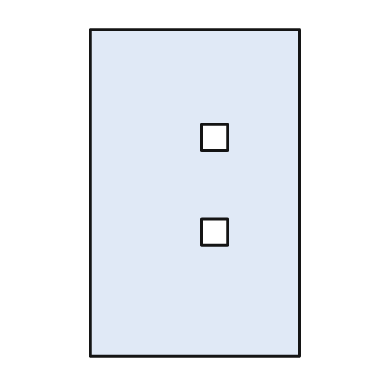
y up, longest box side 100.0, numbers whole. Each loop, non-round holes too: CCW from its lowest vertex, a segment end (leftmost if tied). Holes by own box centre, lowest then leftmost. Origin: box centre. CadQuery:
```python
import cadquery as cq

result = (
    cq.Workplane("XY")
    .moveTo(-32.0, -50.0)
    .lineTo(32.0, -50.0)
    .lineTo(32.0, 50.0)
    .lineTo(-32.0, 50.0)
    .close()
    .moveTo(2.0, -16.0)
    .lineTo(10.0, -16.0)
    .lineTo(10.0, -8.0)
    .lineTo(2.0, -8.0)
    .close()
    .moveTo(2.0, 13.0)
    .lineTo(10.0, 13.0)
    .lineTo(10.0, 21.0)
    .lineTo(2.0, 21.0)
    .close()
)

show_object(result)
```